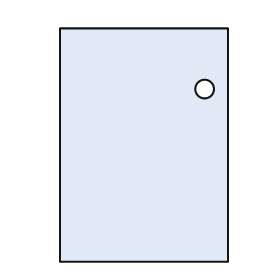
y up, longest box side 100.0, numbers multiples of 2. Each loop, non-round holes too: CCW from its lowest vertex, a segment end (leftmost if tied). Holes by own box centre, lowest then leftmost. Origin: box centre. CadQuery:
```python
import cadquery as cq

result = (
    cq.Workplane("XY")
    .moveTo(-36.0, -50.0)
    .lineTo(36.0, -50.0)
    .lineTo(36.0, 50.0)
    .lineTo(-36.0, 50.0)
    .close()
    .moveTo(26.0, 24.0)
    .circle(4.0)
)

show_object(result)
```